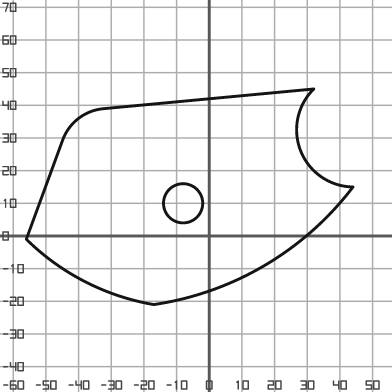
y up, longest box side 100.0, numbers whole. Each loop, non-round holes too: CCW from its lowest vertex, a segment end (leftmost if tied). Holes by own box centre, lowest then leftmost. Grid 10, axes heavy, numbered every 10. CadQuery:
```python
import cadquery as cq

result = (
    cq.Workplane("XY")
    .moveTo(-17.0, -21.0)
    .threePointArc((17.0, -9.0), (44.0, 15.0))
    .threePointArc((28.0, 26.0), (32.0, 45.0))
    .lineTo(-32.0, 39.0)
    .threePointArc((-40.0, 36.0), (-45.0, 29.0))
    .lineTo(-56.0, -1.0)
    .threePointArc((-38.0, -14.0), (-17.0, -21.0))
    .close()
    .moveTo(-8.0, 10.0)
    .circle(6.0)
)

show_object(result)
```